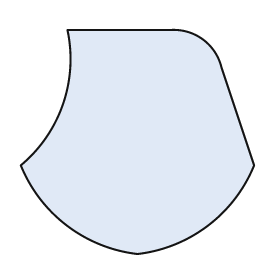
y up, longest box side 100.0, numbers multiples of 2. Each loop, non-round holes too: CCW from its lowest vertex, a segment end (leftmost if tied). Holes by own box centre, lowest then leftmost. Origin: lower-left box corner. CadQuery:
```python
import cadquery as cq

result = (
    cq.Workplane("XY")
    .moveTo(50.0, 0.0)
    .threePointArc((80.0, 12.0), (100.0, 38.0))
    .lineTo(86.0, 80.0)
    .threePointArc((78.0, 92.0), (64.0, 96.0))
    .lineTo(20.0, 96.0)
    .threePointArc((18.0, 64.0), (0.0, 38.0))
    .threePointArc((20.0, 12.0), (50.0, 0.0))
    .close()
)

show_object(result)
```